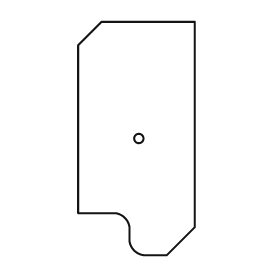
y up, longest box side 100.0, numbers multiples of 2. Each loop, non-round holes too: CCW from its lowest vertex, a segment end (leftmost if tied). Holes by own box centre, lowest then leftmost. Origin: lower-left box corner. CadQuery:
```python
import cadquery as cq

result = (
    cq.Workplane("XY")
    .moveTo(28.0, 0.0)
    .lineTo(38.0, 0.0)
    .lineTo(50.0, 12.0)
    .lineTo(50.0, 100.0)
    .lineTo(10.0, 100.0)
    .lineTo(0.0, 90.0)
    .lineTo(0.0, 18.0)
    .lineTo(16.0, 18.0)
    .threePointArc((20.0, 16.0), (22.0, 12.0))
    .lineTo(22.0, 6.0)
    .threePointArc((24.0, 2.0), (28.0, 0.0))
    .close()
    .moveTo(26.0, 50.0)
    .circle(2.0)
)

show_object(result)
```